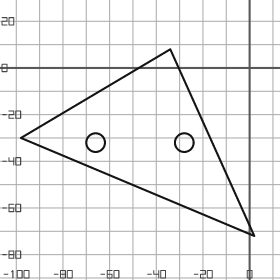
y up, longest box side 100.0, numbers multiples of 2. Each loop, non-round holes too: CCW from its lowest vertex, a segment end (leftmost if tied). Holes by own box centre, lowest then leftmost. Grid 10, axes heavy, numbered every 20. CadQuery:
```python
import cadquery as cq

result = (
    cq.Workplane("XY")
    .moveTo(2.0, -72.0)
    .lineTo(-34.0, 8.0)
    .lineTo(-98.0, -30.0)
    .close()
    .moveTo(-66.0, -32.0)
    .circle(4.0)
    .moveTo(-28.0, -32.0)
    .circle(4.0)
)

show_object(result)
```